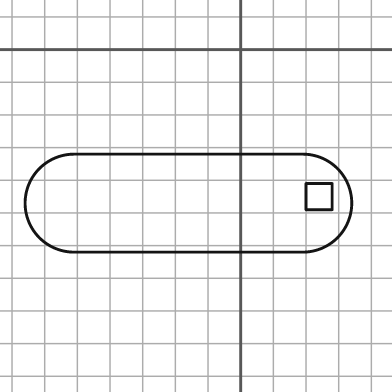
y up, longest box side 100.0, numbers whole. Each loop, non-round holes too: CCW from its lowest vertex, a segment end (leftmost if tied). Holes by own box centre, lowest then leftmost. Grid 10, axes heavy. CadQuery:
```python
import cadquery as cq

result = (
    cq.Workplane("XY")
    .moveTo(-51.0, -62.0)
    .lineTo(19.0, -62.0)
    .threePointArc((34.0, -47.0), (19.0, -32.0))
    .lineTo(-51.0, -32.0)
    .threePointArc((-66.0, -47.0), (-51.0, -62.0))
    .close()
    .moveTo(20.0, -49.0)
    .lineTo(28.0, -49.0)
    .lineTo(28.0, -41.0)
    .lineTo(20.0, -41.0)
    .close()
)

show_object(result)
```